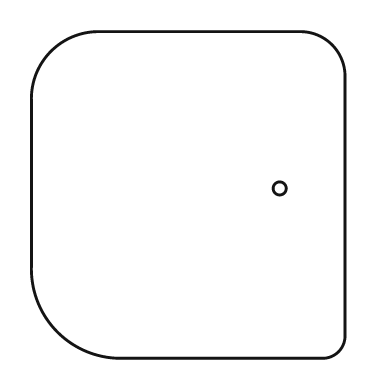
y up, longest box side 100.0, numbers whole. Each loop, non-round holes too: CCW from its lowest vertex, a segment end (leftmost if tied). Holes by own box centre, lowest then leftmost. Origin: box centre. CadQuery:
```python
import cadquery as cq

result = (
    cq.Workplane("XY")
    .moveTo(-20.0, -50.0)
    .lineTo(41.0, -50.0)
    .threePointArc((46.0, -48.0), (48.0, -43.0))
    .lineTo(48.0, 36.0)
    .threePointArc((44.0, 46.0), (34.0, 50.0))
    .lineTo(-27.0, 50.0)
    .threePointArc((-42.0, 44.0), (-48.0, 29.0))
    .lineTo(-48.0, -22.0)
    .threePointArc((-40.0, -42.0), (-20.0, -50.0))
    .close()
    .moveTo(28.0, 2.0)
    .circle(2.0)
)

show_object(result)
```